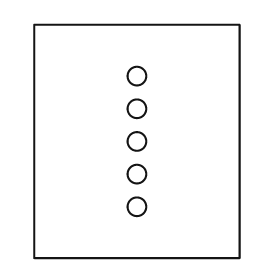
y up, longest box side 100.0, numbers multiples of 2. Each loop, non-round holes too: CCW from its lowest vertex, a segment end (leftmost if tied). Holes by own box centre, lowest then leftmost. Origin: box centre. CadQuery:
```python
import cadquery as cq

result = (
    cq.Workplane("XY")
    .moveTo(-44.0, -50.0)
    .lineTo(44.0, -50.0)
    .lineTo(44.0, 50.0)
    .lineTo(-44.0, 50.0)
    .close()
    .moveTo(0.0, -28.0)
    .circle(4.0)
    .moveTo(0.0, -14.0)
    .circle(4.0)
    .moveTo(0.0, 0.0)
    .circle(4.0)
    .moveTo(0.0, 14.0)
    .circle(4.0)
    .moveTo(0.0, 28.0)
    .circle(4.0)
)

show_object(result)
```